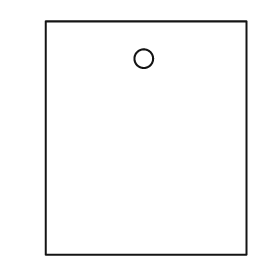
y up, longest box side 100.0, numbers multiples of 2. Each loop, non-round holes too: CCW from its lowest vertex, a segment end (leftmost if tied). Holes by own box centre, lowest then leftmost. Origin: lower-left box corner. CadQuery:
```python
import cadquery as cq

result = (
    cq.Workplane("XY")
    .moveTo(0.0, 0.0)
    .lineTo(86.0, 0.0)
    .lineTo(86.0, 100.0)
    .lineTo(0.0, 100.0)
    .close()
    .moveTo(42.0, 84.0)
    .circle(4.0)
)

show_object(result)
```